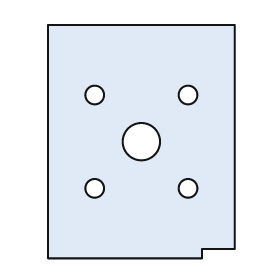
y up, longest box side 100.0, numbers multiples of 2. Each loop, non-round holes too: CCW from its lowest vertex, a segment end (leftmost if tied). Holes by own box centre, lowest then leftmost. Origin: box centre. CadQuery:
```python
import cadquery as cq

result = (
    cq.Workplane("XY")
    .moveTo(-40.0, -50.0)
    .lineTo(26.0, -50.0)
    .lineTo(26.0, -46.0)
    .lineTo(40.0, -46.0)
    .lineTo(40.0, 50.0)
    .lineTo(-40.0, 50.0)
    .close()
    .moveTo(-20.0, -20.0)
    .circle(4.0)
    .moveTo(20.0, -20.0)
    .circle(4.0)
    .moveTo(0.0, 0.0)
    .circle(8.0)
    .moveTo(-20.0, 20.0)
    .circle(4.0)
    .moveTo(20.0, 20.0)
    .circle(4.0)
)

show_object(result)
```